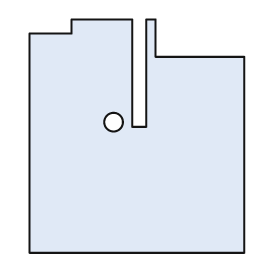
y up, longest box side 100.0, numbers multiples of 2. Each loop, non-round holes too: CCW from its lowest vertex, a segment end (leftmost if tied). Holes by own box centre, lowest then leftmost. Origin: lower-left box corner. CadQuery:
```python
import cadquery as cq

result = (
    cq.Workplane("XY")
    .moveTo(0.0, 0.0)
    .lineTo(92.0, 0.0)
    .lineTo(92.0, 84.0)
    .lineTo(54.0, 84.0)
    .lineTo(54.0, 100.0)
    .lineTo(50.0, 100.0)
    .lineTo(50.0, 54.0)
    .lineTo(44.0, 54.0)
    .lineTo(44.0, 100.0)
    .lineTo(18.0, 100.0)
    .lineTo(18.0, 94.0)
    .lineTo(0.0, 94.0)
    .close()
    .moveTo(36.0, 56.0)
    .circle(4.0)
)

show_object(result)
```